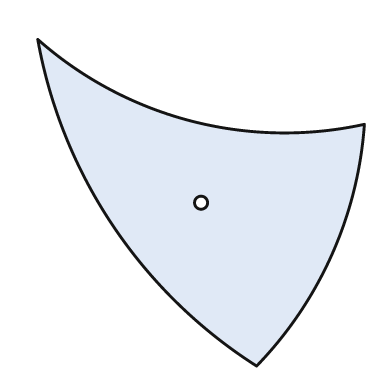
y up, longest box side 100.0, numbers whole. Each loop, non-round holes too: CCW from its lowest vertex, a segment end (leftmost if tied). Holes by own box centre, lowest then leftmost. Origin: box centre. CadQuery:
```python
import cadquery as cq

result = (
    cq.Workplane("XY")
    .moveTo(17.0, -50.0)
    .threePointArc((40.0, -16.0), (50.0, 24.0))
    .threePointArc((-3.0, 25.0), (-50.0, 50.0))
    .threePointArc((-27.0, -7.0), (17.0, -50.0))
    .close()
    .moveTo(0.0, 0.0)
    .circle(2.0)
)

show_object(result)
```